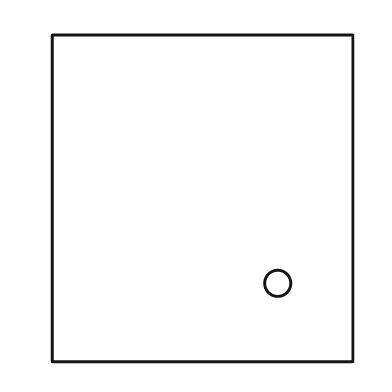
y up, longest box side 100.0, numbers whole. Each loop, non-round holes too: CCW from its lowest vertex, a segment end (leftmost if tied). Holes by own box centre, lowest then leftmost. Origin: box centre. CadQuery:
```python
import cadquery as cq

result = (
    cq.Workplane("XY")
    .moveTo(-46.0, -50.0)
    .lineTo(46.0, -50.0)
    .lineTo(46.0, 50.0)
    .lineTo(-46.0, 50.0)
    .close()
    .moveTo(23.0, -26.0)
    .circle(4.0)
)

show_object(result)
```